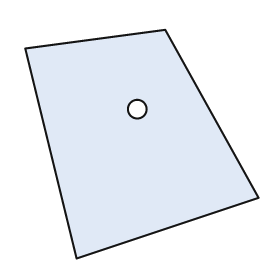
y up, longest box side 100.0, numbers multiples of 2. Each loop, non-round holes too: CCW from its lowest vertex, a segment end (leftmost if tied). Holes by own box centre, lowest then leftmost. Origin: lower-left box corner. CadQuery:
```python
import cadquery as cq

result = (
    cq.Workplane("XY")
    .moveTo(22.0, 0.0)
    .lineTo(100.0, 26.0)
    .lineTo(60.0, 98.0)
    .lineTo(0.0, 90.0)
    .close()
    .moveTo(48.0, 64.0)
    .circle(4.0)
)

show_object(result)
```